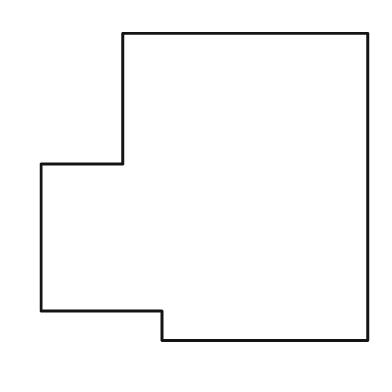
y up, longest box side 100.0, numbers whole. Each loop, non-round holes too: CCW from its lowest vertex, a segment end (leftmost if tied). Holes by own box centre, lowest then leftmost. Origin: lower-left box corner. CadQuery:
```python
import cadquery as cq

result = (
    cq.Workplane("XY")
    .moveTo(37.0, 0.0)
    .lineTo(100.0, 0.0)
    .lineTo(100.0, 94.0)
    .lineTo(25.0, 94.0)
    .lineTo(25.0, 54.0)
    .lineTo(0.0, 54.0)
    .lineTo(0.0, 9.0)
    .lineTo(37.0, 9.0)
    .close()
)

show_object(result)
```